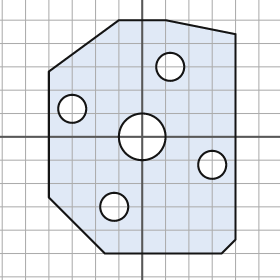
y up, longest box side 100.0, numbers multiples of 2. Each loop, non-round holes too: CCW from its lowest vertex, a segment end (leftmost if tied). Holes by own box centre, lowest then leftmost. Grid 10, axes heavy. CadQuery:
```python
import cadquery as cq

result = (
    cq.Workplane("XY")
    .moveTo(-16.0, -50.0)
    .lineTo(34.0, -50.0)
    .lineTo(40.0, -44.0)
    .lineTo(40.0, 44.0)
    .lineTo(10.0, 50.0)
    .lineTo(-10.0, 50.0)
    .lineTo(-40.0, 28.0)
    .lineTo(-40.0, -26.0)
    .close()
    .moveTo(-12.0, -30.0)
    .circle(6.0)
    .moveTo(30.0, -12.0)
    .circle(6.0)
    .moveTo(0.0, 0.0)
    .circle(10.0)
    .moveTo(-30.0, 12.0)
    .circle(6.0)
    .moveTo(12.0, 30.0)
    .circle(6.0)
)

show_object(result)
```